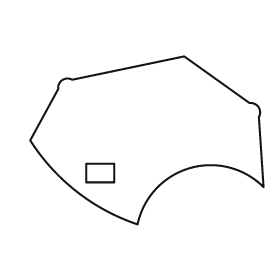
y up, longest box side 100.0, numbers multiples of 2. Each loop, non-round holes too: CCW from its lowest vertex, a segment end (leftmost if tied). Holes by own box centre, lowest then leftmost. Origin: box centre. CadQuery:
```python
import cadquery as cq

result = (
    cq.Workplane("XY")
    .moveTo(-4.0, -36.0)
    .threePointArc((18.0, -12.0), (50.0, -20.0))
    .lineTo(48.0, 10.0)
    .threePointArc((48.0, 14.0), (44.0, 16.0))
    .lineTo(16.0, 36.0)
    .lineTo(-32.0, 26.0)
    .threePointArc((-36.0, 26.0), (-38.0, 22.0))
    .lineTo(-50.0, 0.0)
    .threePointArc((-30.0, -22.0), (-4.0, -36.0))
    .close()
    .moveTo(-26.0, -18.0)
    .lineTo(-14.0, -18.0)
    .lineTo(-14.0, -10.0)
    .lineTo(-26.0, -10.0)
    .close()
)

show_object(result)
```